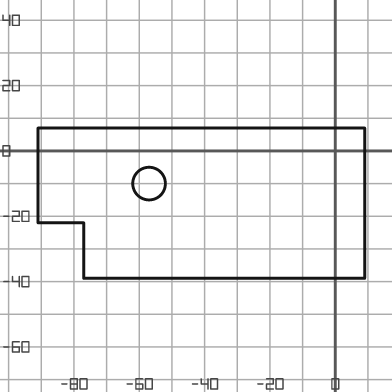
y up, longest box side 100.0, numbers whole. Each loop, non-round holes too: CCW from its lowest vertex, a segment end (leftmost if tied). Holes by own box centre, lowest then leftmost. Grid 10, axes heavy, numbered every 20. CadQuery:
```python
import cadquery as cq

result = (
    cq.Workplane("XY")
    .moveTo(-77.0, -39.0)
    .lineTo(9.0, -39.0)
    .lineTo(9.0, 7.0)
    .lineTo(-91.0, 7.0)
    .lineTo(-91.0, -22.0)
    .lineTo(-77.0, -22.0)
    .close()
    .moveTo(-57.0, -10.0)
    .circle(5.0)
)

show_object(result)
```